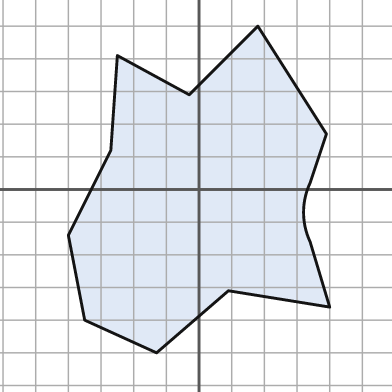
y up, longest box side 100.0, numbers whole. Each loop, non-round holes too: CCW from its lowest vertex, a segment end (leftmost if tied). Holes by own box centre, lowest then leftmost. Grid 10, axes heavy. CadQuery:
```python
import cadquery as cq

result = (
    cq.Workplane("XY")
    .moveTo(-13.0, -50.0)
    .lineTo(9.0, -31.0)
    .lineTo(40.0, -36.0)
    .lineTo(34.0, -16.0)
    .threePointArc((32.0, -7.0), (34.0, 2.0))
    .lineTo(39.0, 17.0)
    .lineTo(18.0, 50.0)
    .lineTo(-3.0, 29.0)
    .lineTo(-25.0, 41.0)
    .lineTo(-27.0, 12.0)
    .lineTo(-40.0, -14.0)
    .lineTo(-35.0, -40.0)
    .close()
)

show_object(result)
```